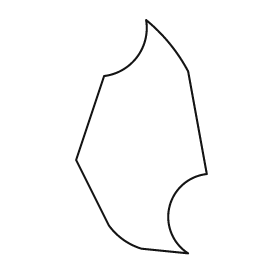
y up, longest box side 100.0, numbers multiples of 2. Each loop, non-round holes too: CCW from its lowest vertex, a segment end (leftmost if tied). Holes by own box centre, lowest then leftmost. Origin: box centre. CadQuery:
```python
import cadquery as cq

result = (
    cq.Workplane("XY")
    .moveTo(20.0, -50.0)
    .threePointArc((12.0, -30.0), (28.0, -16.0))
    .lineTo(20.0, 28.0)
    .threePointArc((12.0, 40.0), (2.0, 50.0))
    .threePointArc((-2.0, 34.0), (-16.0, 26.0))
    .lineTo(-28.0, -10.0)
    .lineTo(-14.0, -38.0)
    .threePointArc((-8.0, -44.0), (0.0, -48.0))
    .close()
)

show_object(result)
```